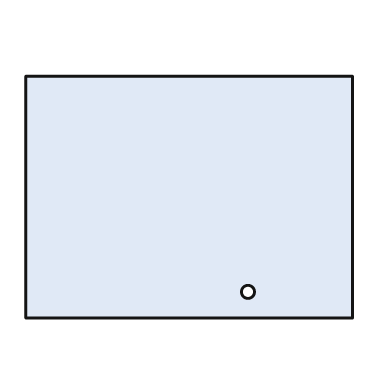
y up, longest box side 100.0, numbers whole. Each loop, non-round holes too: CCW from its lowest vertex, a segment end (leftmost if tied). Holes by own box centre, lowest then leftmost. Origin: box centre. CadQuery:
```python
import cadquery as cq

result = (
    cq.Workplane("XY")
    .moveTo(-50.0, -37.0)
    .lineTo(50.0, -37.0)
    .lineTo(50.0, 37.0)
    .lineTo(-50.0, 37.0)
    .close()
    .moveTo(18.0, -29.0)
    .circle(2.0)
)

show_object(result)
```